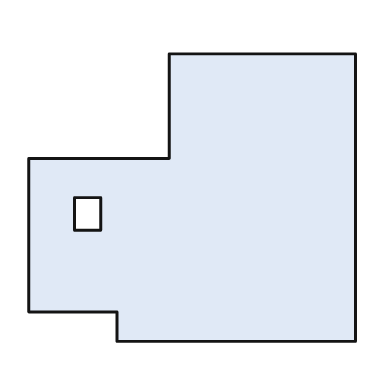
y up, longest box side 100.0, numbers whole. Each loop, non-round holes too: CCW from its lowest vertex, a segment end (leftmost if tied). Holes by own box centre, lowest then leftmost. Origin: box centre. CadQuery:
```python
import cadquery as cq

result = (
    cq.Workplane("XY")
    .moveTo(-23.0, -44.0)
    .lineTo(50.0, -44.0)
    .lineTo(50.0, 44.0)
    .lineTo(-7.0, 44.0)
    .lineTo(-7.0, 12.0)
    .lineTo(-50.0, 12.0)
    .lineTo(-50.0, -35.0)
    .lineTo(-23.0, -35.0)
    .close()
    .moveTo(-36.0, -10.0)
    .lineTo(-28.0, -10.0)
    .lineTo(-28.0, 0.0)
    .lineTo(-36.0, 0.0)
    .close()
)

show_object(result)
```